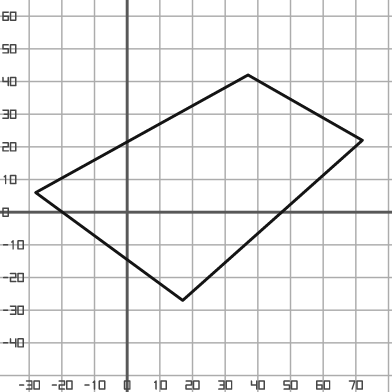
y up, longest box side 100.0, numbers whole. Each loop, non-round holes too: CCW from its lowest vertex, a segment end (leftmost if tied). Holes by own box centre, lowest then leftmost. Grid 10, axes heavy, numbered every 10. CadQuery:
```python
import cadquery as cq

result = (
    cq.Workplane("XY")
    .moveTo(17.0, -27.0)
    .lineTo(72.0, 22.0)
    .lineTo(37.0, 42.0)
    .lineTo(-28.0, 6.0)
    .close()
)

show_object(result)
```